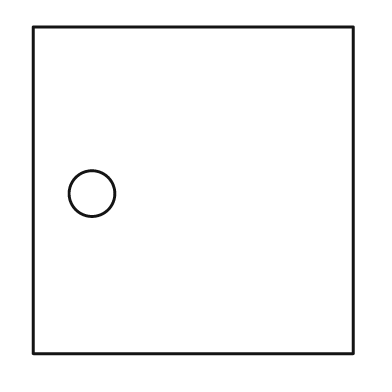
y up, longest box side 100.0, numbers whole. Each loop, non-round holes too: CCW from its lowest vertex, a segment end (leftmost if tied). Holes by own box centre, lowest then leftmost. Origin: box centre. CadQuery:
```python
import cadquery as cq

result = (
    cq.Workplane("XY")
    .moveTo(-49.0, -50.0)
    .lineTo(49.0, -50.0)
    .lineTo(49.0, 50.0)
    .lineTo(-49.0, 50.0)
    .close()
    .moveTo(-31.0, -1.0)
    .circle(7.0)
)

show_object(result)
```